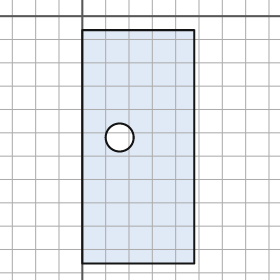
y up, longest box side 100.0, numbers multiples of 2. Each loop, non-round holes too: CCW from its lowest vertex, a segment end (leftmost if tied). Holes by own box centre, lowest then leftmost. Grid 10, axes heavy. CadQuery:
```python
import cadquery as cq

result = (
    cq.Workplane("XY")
    .moveTo(0.0, -106.0)
    .lineTo(48.0, -106.0)
    .lineTo(48.0, -6.0)
    .lineTo(0.0, -6.0)
    .close()
    .moveTo(16.0, -52.0)
    .circle(6.0)
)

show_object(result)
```